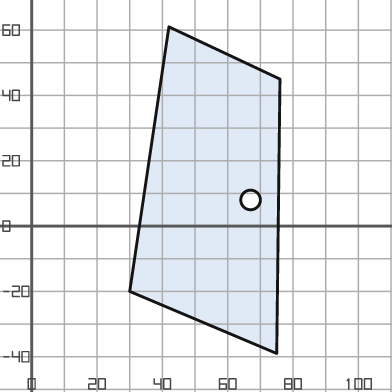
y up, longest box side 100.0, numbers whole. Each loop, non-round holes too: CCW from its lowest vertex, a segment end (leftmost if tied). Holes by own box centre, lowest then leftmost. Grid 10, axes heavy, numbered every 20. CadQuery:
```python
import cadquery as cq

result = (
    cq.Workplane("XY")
    .moveTo(75.0, -39.0)
    .lineTo(76.0, 45.0)
    .lineTo(42.0, 61.0)
    .lineTo(30.0, -20.0)
    .close()
    .moveTo(67.0, 8.0)
    .circle(3.0)
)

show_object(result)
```